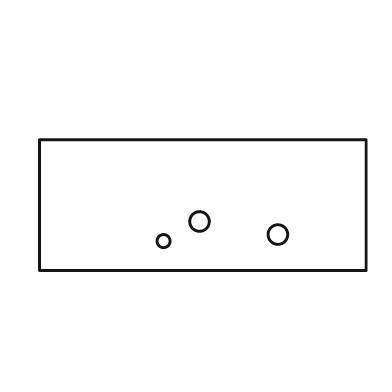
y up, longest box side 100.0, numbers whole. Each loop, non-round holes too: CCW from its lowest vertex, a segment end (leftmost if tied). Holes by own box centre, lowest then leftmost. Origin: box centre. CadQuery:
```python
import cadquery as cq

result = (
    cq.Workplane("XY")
    .moveTo(-50.0, -20.0)
    .lineTo(50.0, -20.0)
    .lineTo(50.0, 20.0)
    .lineTo(-50.0, 20.0)
    .close()
    .moveTo(-12.0, -11.0)
    .circle(2.0)
    .moveTo(23.0, -9.0)
    .circle(3.0)
    .moveTo(-1.0, -5.0)
    .circle(3.0)
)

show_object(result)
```